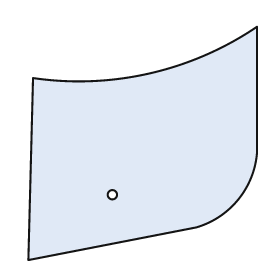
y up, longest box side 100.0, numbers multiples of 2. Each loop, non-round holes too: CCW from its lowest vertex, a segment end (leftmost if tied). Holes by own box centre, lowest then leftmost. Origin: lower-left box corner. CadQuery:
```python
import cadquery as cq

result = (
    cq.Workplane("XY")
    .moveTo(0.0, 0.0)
    .lineTo(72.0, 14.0)
    .threePointArc((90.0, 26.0), (98.0, 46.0))
    .lineTo(98.0, 100.0)
    .threePointArc((52.0, 80.0), (2.0, 78.0))
    .close()
    .moveTo(36.0, 28.0)
    .circle(2.0)
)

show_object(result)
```